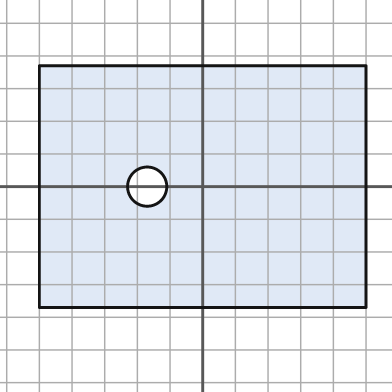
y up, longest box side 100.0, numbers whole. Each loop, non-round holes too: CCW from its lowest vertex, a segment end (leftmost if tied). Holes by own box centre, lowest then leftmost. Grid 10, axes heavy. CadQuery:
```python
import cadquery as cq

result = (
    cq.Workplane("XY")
    .moveTo(-50.0, -37.0)
    .lineTo(50.0, -37.0)
    .lineTo(50.0, 37.0)
    .lineTo(-50.0, 37.0)
    .close()
    .moveTo(-17.0, 0.0)
    .circle(6.0)
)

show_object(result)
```